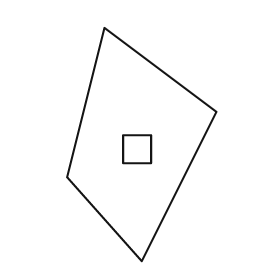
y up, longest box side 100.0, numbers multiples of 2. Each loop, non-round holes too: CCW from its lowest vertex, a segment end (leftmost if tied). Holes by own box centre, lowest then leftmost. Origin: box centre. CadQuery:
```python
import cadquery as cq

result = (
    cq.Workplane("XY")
    .moveTo(0.0, -50.0)
    .lineTo(32.0, 14.0)
    .lineTo(-16.0, 50.0)
    .lineTo(-32.0, -14.0)
    .close()
    .moveTo(-8.0, -8.0)
    .lineTo(4.0, -8.0)
    .lineTo(4.0, 4.0)
    .lineTo(-8.0, 4.0)
    .close()
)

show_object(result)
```